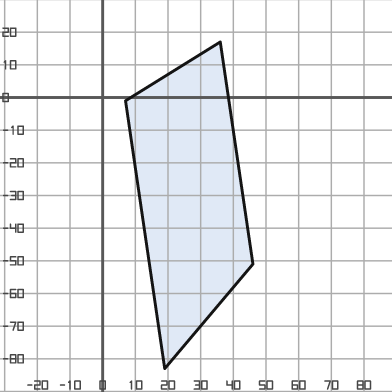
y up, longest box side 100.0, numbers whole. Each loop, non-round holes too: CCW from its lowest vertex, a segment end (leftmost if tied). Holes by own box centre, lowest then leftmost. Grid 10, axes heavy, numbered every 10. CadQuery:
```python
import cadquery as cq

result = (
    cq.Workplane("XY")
    .moveTo(19.0, -83.0)
    .lineTo(46.0, -51.0)
    .lineTo(36.0, 17.0)
    .lineTo(7.0, -1.0)
    .close()
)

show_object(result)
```